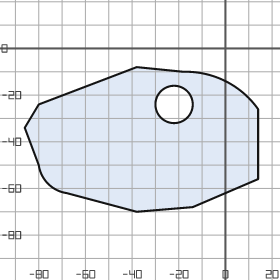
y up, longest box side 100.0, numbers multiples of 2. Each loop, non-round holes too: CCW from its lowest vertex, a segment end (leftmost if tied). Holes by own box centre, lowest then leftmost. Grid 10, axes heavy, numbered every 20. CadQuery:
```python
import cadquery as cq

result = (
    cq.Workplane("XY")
    .moveTo(-38.0, -70.0)
    .lineTo(-14.0, -68.0)
    .lineTo(14.0, -56.0)
    .lineTo(14.0, -26.0)
    .threePointArc((0.0, -14.0), (-18.0, -10.0))
    .lineTo(-38.0, -8.0)
    .lineTo(-80.0, -24.0)
    .lineTo(-86.0, -34.0)
    .lineTo(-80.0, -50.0)
    .threePointArc((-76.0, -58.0), (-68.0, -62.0))
    .close()
    .moveTo(-22.0, -24.0)
    .circle(8.0)
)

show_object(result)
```